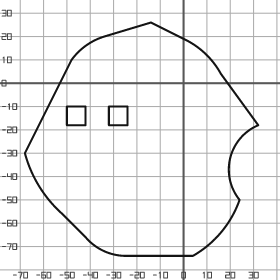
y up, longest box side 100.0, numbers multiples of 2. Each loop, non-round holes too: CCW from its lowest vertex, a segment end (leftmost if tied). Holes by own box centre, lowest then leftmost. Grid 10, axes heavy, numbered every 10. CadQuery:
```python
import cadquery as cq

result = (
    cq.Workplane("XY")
    .moveTo(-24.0, -74.0)
    .lineTo(4.0, -74.0)
    .threePointArc((16.0, -64.0), (24.0, -50.0))
    .threePointArc((20.0, -32.0), (32.0, -18.0))
    .lineTo(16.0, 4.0)
    .threePointArc((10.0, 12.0), (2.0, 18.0))
    .lineTo(-14.0, 26.0)
    .lineTo(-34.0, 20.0)
    .threePointArc((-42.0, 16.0), (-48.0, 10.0))
    .lineTo(-68.0, -30.0)
    .threePointArc((-62.0, -44.0), (-52.0, -56.0))
    .lineTo(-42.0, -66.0)
    .threePointArc((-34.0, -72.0), (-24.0, -74.0))
    .close()
    .moveTo(-50.0, -18.0)
    .lineTo(-42.0, -18.0)
    .lineTo(-42.0, -10.0)
    .lineTo(-50.0, -10.0)
    .close()
    .moveTo(-32.0, -18.0)
    .lineTo(-24.0, -18.0)
    .lineTo(-24.0, -10.0)
    .lineTo(-32.0, -10.0)
    .close()
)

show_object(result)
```